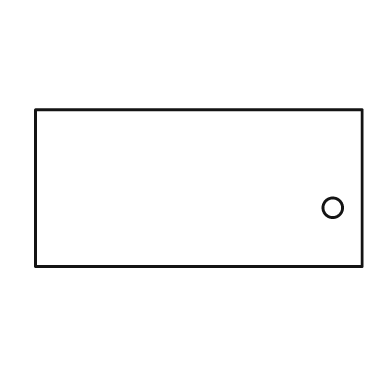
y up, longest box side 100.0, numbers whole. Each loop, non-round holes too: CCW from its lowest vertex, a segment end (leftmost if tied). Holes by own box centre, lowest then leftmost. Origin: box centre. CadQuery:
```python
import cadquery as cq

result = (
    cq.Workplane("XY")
    .moveTo(-50.0, -24.0)
    .lineTo(50.0, -24.0)
    .lineTo(50.0, 24.0)
    .lineTo(-50.0, 24.0)
    .close()
    .moveTo(41.0, -6.0)
    .circle(3.0)
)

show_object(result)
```